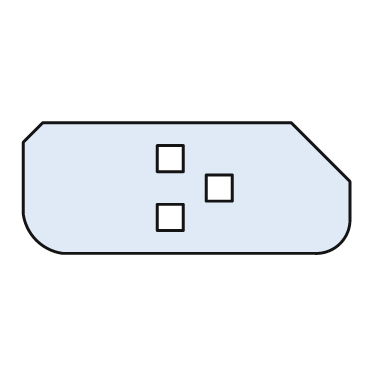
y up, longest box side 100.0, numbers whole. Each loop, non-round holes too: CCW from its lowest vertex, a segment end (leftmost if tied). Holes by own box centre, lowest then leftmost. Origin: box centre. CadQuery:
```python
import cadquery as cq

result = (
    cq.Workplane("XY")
    .moveTo(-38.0, -20.0)
    .lineTo(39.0, -20.0)
    .threePointArc((47.0, -17.0), (50.0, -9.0))
    .lineTo(50.0, 2.0)
    .lineTo(32.0, 20.0)
    .lineTo(-44.0, 20.0)
    .lineTo(-50.0, 14.0)
    .lineTo(-50.0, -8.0)
    .threePointArc((-46.0, -16.0), (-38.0, -20.0))
    .close()
    .moveTo(-9.0, -13.0)
    .lineTo(-1.0, -13.0)
    .lineTo(-1.0, -5.0)
    .lineTo(-9.0, -5.0)
    .close()
    .moveTo(6.0, -4.0)
    .lineTo(14.0, -4.0)
    .lineTo(14.0, 4.0)
    .lineTo(6.0, 4.0)
    .close()
    .moveTo(-9.0, 5.0)
    .lineTo(-1.0, 5.0)
    .lineTo(-1.0, 13.0)
    .lineTo(-9.0, 13.0)
    .close()
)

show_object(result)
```